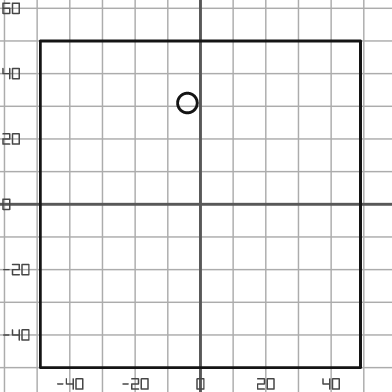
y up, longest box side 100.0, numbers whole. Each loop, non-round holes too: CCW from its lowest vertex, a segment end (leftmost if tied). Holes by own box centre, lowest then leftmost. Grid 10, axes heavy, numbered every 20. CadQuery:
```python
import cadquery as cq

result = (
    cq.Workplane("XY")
    .moveTo(-49.0, -50.0)
    .lineTo(49.0, -50.0)
    .lineTo(49.0, 50.0)
    .lineTo(-49.0, 50.0)
    .close()
    .moveTo(-4.0, 31.0)
    .circle(3.0)
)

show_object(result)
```